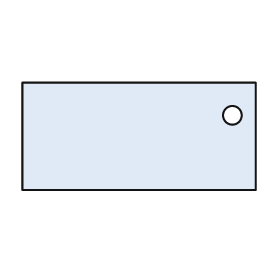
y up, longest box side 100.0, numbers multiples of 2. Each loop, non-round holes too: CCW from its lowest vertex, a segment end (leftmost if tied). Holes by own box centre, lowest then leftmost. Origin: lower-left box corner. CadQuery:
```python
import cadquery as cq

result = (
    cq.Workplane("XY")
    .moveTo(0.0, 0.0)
    .lineTo(100.0, 0.0)
    .lineTo(100.0, 46.0)
    .lineTo(0.0, 46.0)
    .close()
    .moveTo(90.0, 32.0)
    .circle(4.0)
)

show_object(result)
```